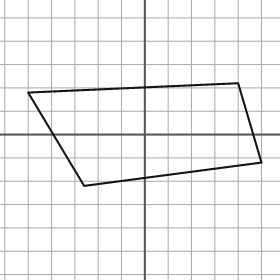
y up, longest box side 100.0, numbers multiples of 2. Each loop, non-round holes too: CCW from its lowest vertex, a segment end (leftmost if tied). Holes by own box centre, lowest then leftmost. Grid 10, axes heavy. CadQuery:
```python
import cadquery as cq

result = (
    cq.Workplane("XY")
    .moveTo(-26.0, -22.0)
    .lineTo(50.0, -12.0)
    .lineTo(40.0, 22.0)
    .lineTo(-50.0, 18.0)
    .close()
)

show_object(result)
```